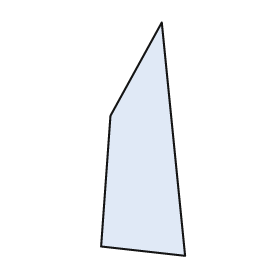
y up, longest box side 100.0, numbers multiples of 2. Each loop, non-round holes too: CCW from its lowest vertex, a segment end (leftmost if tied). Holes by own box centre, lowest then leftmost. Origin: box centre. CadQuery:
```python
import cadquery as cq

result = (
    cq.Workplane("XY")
    .moveTo(18.0, -50.0)
    .lineTo(8.0, 50.0)
    .lineTo(-14.0, 10.0)
    .lineTo(-18.0, -46.0)
    .close()
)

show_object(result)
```